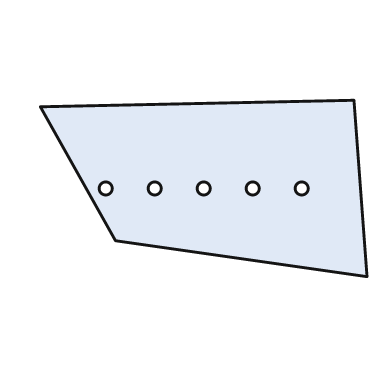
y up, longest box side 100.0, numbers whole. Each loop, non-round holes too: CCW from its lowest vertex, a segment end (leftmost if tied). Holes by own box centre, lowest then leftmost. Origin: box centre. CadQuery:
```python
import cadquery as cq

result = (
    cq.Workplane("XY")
    .moveTo(50.0, -27.0)
    .lineTo(46.0, 27.0)
    .lineTo(-50.0, 25.0)
    .lineTo(-27.0, -16.0)
    .close()
    .moveTo(-30.0, 0.0)
    .circle(2.0)
    .moveTo(-15.0, 0.0)
    .circle(2.0)
    .moveTo(0.0, 0.0)
    .circle(2.0)
    .moveTo(15.0, 0.0)
    .circle(2.0)
    .moveTo(30.0, 0.0)
    .circle(2.0)
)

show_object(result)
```